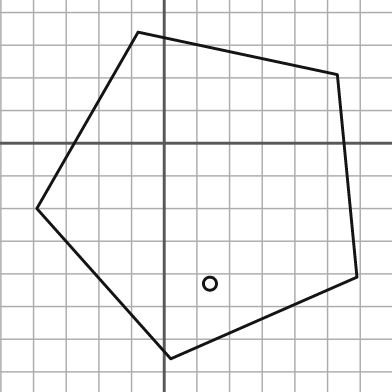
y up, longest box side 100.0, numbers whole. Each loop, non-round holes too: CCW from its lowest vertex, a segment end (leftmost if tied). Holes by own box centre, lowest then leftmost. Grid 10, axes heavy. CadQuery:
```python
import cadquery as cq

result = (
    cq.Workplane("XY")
    .moveTo(2.0, -66.0)
    .lineTo(59.0, -41.0)
    .lineTo(53.0, 21.0)
    .lineTo(-8.0, 34.0)
    .lineTo(-39.0, -20.0)
    .close()
    .moveTo(14.0, -43.0)
    .circle(2.0)
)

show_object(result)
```